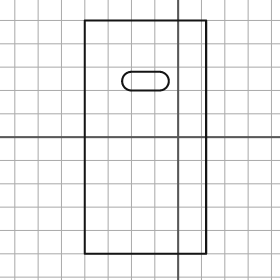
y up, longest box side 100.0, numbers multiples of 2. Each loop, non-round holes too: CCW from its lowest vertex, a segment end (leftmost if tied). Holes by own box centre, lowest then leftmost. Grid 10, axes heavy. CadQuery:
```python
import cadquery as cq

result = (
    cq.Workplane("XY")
    .moveTo(-40.0, -50.0)
    .lineTo(12.0, -50.0)
    .lineTo(12.0, 50.0)
    .lineTo(-40.0, 50.0)
    .close()
    .moveTo(-20.0, 20.0)
    .lineTo(-8.0, 20.0)
    .threePointArc((-4.0, 24.0), (-8.0, 28.0))
    .lineTo(-20.0, 28.0)
    .threePointArc((-24.0, 24.0), (-20.0, 20.0))
    .close()
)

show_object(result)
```